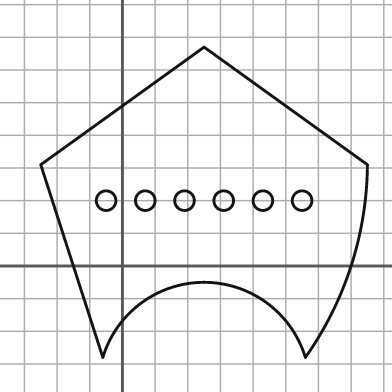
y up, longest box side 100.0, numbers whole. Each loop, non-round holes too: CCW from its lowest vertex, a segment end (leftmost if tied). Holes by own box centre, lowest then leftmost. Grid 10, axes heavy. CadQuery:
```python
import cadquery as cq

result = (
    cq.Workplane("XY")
    .moveTo(-6.0, -28.0)
    .threePointArc((25.0, -5.0), (56.0, -28.0))
    .threePointArc((70.0, 0.0), (75.0, 31.0))
    .lineTo(25.0, 67.0)
    .lineTo(-25.0, 31.0)
    .close()
    .moveTo(-5.0, 20.0)
    .circle(3.0)
    .moveTo(7.0, 20.0)
    .circle(3.0)
    .moveTo(19.0, 20.0)
    .circle(3.0)
    .moveTo(31.0, 20.0)
    .circle(3.0)
    .moveTo(43.0, 20.0)
    .circle(3.0)
    .moveTo(55.0, 20.0)
    .circle(3.0)
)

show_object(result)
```